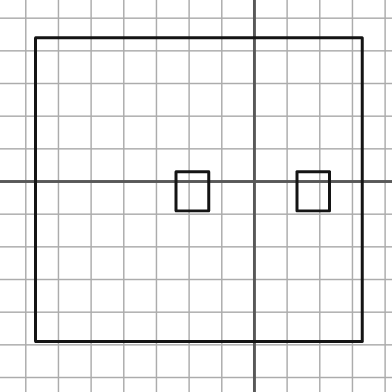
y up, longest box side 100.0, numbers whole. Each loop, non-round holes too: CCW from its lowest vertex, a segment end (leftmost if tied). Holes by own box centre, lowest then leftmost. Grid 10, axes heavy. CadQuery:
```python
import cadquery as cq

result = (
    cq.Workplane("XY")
    .moveTo(-67.0, -49.0)
    .lineTo(33.0, -49.0)
    .lineTo(33.0, 44.0)
    .lineTo(-67.0, 44.0)
    .close()
    .moveTo(-24.0, -9.0)
    .lineTo(-14.0, -9.0)
    .lineTo(-14.0, 3.0)
    .lineTo(-24.0, 3.0)
    .close()
    .moveTo(13.0, -9.0)
    .lineTo(23.0, -9.0)
    .lineTo(23.0, 3.0)
    .lineTo(13.0, 3.0)
    .close()
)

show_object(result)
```